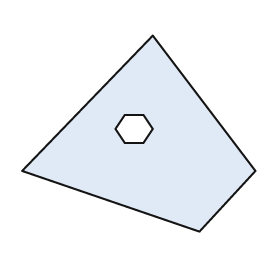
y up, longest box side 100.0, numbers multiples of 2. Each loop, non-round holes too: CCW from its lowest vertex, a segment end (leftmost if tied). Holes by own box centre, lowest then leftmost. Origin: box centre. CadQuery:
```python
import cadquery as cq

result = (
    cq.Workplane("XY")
    .moveTo(26.0, -42.0)
    .lineTo(50.0, -16.0)
    .lineTo(6.0, 42.0)
    .lineTo(-50.0, -16.0)
    .close()
    .moveTo(-6.0, -4.0)
    .lineTo(2.0, -4.0)
    .lineTo(6.0, 2.0)
    .lineTo(2.0, 8.0)
    .lineTo(-6.0, 8.0)
    .lineTo(-10.0, 2.0)
    .close()
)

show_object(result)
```